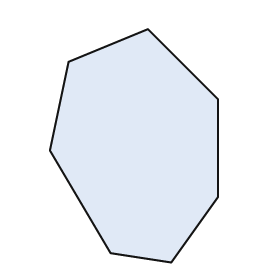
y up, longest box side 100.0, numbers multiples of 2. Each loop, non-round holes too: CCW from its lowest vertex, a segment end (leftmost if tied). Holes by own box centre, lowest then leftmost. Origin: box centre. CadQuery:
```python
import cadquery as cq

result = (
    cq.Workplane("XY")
    .moveTo(16.0, -50.0)
    .lineTo(36.0, -22.0)
    .lineTo(36.0, 20.0)
    .lineTo(6.0, 50.0)
    .lineTo(-28.0, 36.0)
    .lineTo(-36.0, -2.0)
    .lineTo(-10.0, -46.0)
    .close()
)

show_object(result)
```